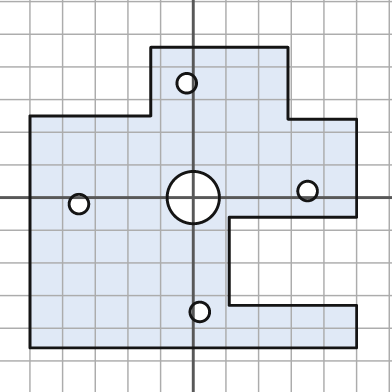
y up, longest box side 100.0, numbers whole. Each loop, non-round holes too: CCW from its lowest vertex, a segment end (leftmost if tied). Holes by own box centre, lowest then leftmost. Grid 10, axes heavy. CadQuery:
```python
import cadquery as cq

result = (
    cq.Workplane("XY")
    .moveTo(-50.0, -46.0)
    .lineTo(50.0, -46.0)
    .lineTo(50.0, -33.0)
    .lineTo(11.0, -33.0)
    .lineTo(11.0, -6.0)
    .lineTo(50.0, -6.0)
    .lineTo(50.0, 24.0)
    .lineTo(29.0, 24.0)
    .lineTo(29.0, 46.0)
    .lineTo(-13.0, 46.0)
    .lineTo(-13.0, 25.0)
    .lineTo(-50.0, 25.0)
    .close()
    .moveTo(2.0, -35.0)
    .circle(3.0)
    .moveTo(-35.0, -2.0)
    .circle(3.0)
    .moveTo(0.0, 0.0)
    .circle(8.0)
    .moveTo(35.0, 2.0)
    .circle(3.0)
    .moveTo(-2.0, 35.0)
    .circle(3.0)
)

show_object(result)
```